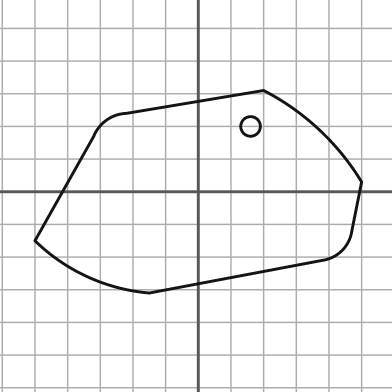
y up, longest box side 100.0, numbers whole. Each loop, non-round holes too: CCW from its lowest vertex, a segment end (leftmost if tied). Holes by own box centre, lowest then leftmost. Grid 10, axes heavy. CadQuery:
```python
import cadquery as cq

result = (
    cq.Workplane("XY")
    .moveTo(-15.0, -31.0)
    .lineTo(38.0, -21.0)
    .threePointArc((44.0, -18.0), (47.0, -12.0))
    .lineTo(50.0, 3.0)
    .threePointArc((37.0, 19.0), (20.0, 31.0))
    .lineTo(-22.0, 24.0)
    .threePointArc((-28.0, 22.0), (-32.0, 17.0))
    .lineTo(-50.0, -15.0)
    .threePointArc((-34.0, -26.0), (-15.0, -31.0))
    .close()
    .moveTo(16.0, 20.0)
    .circle(3.0)
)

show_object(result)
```